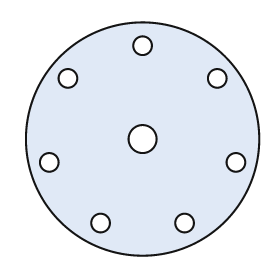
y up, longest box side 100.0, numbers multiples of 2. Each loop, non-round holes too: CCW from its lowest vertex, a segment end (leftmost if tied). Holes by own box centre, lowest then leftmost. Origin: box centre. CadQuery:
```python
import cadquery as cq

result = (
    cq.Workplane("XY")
    .moveTo(0.0, 0.0)
    .circle(50.0)
    .moveTo(-18.0, -36.0)
    .circle(4.0)
    .moveTo(18.0, -36.0)
    .circle(4.0)
    .moveTo(-40.0, -10.0)
    .circle(4.0)
    .moveTo(40.0, -10.0)
    .circle(4.0)
    .moveTo(0.0, 0.0)
    .circle(6.0)
    .moveTo(-32.0, 26.0)
    .circle(4.0)
    .moveTo(32.0, 26.0)
    .circle(4.0)
    .moveTo(0.0, 40.0)
    .circle(4.0)
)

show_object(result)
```